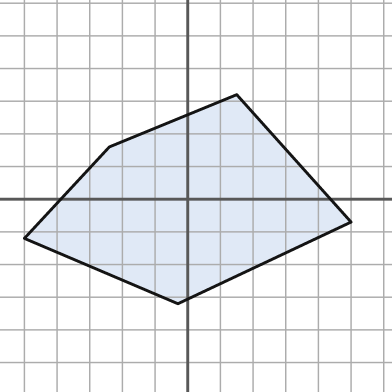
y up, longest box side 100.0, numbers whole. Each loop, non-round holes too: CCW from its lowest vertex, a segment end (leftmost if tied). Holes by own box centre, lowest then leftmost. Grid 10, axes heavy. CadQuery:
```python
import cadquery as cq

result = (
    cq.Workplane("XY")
    .moveTo(-3.0, -32.0)
    .lineTo(50.0, -7.0)
    .lineTo(15.0, 32.0)
    .lineTo(-24.0, 16.0)
    .lineTo(-50.0, -12.0)
    .close()
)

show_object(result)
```